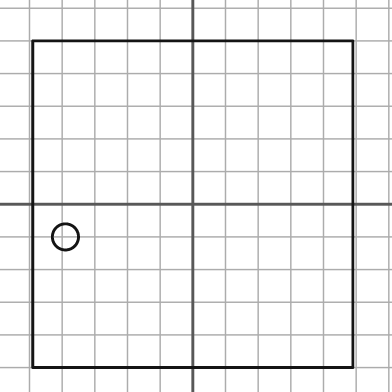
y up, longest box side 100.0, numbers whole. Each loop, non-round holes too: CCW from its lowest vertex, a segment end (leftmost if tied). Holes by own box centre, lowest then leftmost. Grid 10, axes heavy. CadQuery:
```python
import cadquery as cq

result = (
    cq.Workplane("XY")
    .moveTo(-49.0, -50.0)
    .lineTo(49.0, -50.0)
    .lineTo(49.0, 50.0)
    .lineTo(-49.0, 50.0)
    .close()
    .moveTo(-39.0, -10.0)
    .circle(4.0)
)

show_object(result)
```